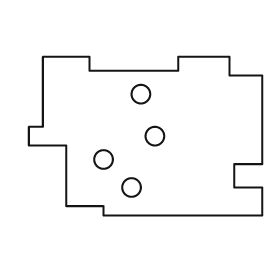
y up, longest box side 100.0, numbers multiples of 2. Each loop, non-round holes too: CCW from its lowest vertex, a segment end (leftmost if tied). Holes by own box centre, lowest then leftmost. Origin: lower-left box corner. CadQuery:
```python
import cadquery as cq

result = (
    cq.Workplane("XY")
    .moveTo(32.0, 0.0)
    .lineTo(100.0, 0.0)
    .lineTo(100.0, 12.0)
    .lineTo(88.0, 12.0)
    .lineTo(88.0, 22.0)
    .lineTo(100.0, 22.0)
    .lineTo(100.0, 60.0)
    .lineTo(86.0, 60.0)
    .lineTo(86.0, 68.0)
    .lineTo(64.0, 68.0)
    .lineTo(64.0, 62.0)
    .lineTo(26.0, 62.0)
    .lineTo(26.0, 68.0)
    .lineTo(6.0, 68.0)
    .lineTo(6.0, 38.0)
    .lineTo(0.0, 38.0)
    .lineTo(0.0, 30.0)
    .lineTo(16.0, 30.0)
    .lineTo(16.0, 4.0)
    .lineTo(32.0, 4.0)
    .close()
    .moveTo(44.0, 12.0)
    .circle(4.0)
    .moveTo(32.0, 24.0)
    .circle(4.0)
    .moveTo(54.0, 34.0)
    .circle(4.0)
    .moveTo(48.0, 52.0)
    .circle(4.0)
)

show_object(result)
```